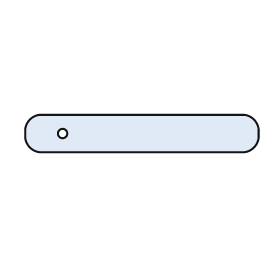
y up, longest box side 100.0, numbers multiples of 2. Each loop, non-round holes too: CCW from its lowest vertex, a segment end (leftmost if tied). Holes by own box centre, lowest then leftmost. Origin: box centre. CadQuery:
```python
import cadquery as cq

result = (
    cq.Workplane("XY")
    .moveTo(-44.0, -8.0)
    .lineTo(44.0, -8.0)
    .threePointArc((48.0, -6.0), (50.0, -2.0))
    .lineTo(50.0, 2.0)
    .threePointArc((48.0, 6.0), (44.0, 8.0))
    .lineTo(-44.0, 8.0)
    .threePointArc((-48.0, 6.0), (-50.0, 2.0))
    .lineTo(-50.0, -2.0)
    .threePointArc((-48.0, -6.0), (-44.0, -8.0))
    .close()
    .moveTo(-34.0, 0.0)
    .circle(2.0)
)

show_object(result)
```